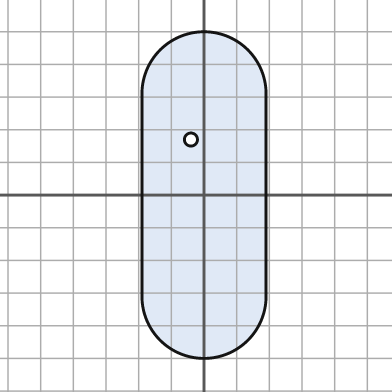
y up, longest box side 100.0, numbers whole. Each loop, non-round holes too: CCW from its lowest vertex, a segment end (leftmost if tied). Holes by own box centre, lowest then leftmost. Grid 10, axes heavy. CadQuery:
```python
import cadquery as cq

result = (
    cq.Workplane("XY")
    .moveTo(-19.0, -31.0)
    .threePointArc((0.0, -50.0), (19.0, -31.0))
    .lineTo(19.0, 31.0)
    .threePointArc((0.0, 50.0), (-19.0, 31.0))
    .close()
    .moveTo(-4.0, 17.0)
    .circle(2.0)
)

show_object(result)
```